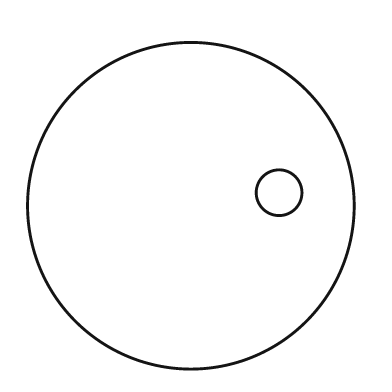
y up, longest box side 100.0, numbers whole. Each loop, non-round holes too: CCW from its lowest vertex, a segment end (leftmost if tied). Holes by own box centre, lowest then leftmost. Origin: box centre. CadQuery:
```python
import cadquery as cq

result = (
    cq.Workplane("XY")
    .moveTo(0.0, 0.0)
    .circle(50.0)
    .moveTo(27.0, 4.0)
    .circle(7.0)
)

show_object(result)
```